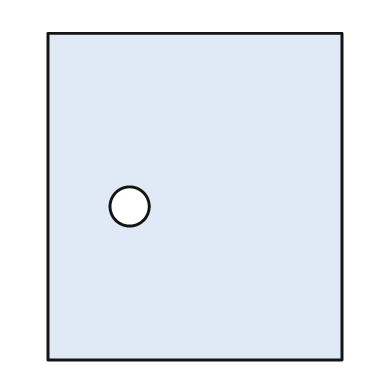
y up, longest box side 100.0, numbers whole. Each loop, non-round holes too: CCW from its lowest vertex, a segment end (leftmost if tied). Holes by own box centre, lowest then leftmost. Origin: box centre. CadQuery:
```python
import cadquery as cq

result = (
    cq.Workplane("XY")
    .moveTo(-45.0, -50.0)
    .lineTo(45.0, -50.0)
    .lineTo(45.0, 50.0)
    .lineTo(-45.0, 50.0)
    .close()
    .moveTo(-20.0, -3.0)
    .circle(6.0)
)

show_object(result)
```